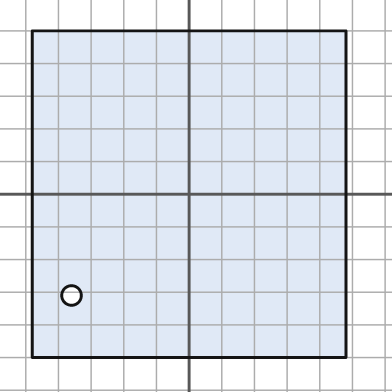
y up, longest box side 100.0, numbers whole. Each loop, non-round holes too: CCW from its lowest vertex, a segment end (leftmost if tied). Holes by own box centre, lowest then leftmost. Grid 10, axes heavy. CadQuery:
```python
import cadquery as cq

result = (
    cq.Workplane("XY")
    .moveTo(-48.0, -50.0)
    .lineTo(48.0, -50.0)
    .lineTo(48.0, 50.0)
    .lineTo(-48.0, 50.0)
    .close()
    .moveTo(-36.0, -31.0)
    .circle(3.0)
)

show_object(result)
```